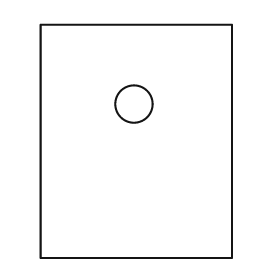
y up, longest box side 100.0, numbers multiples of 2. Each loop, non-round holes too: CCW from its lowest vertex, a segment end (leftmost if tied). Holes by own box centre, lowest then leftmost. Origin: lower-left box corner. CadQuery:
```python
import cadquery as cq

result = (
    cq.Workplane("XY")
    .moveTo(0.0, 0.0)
    .lineTo(82.0, 0.0)
    .lineTo(82.0, 100.0)
    .lineTo(0.0, 100.0)
    .close()
    .moveTo(40.0, 66.0)
    .circle(8.0)
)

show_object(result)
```